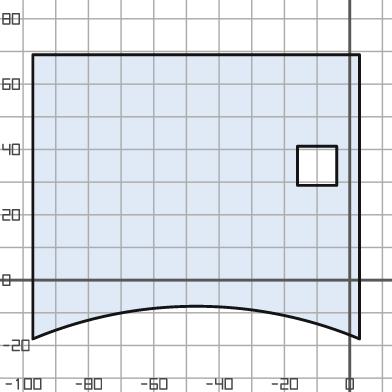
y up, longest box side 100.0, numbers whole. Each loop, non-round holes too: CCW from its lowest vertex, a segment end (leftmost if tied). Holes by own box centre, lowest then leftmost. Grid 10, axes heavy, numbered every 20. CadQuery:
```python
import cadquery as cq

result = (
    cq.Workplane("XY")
    .moveTo(-97.0, -18.0)
    .threePointArc((-47.0, -8.0), (3.0, -18.0))
    .lineTo(3.0, 69.0)
    .lineTo(-97.0, 69.0)
    .close()
    .moveTo(-16.0, 29.0)
    .lineTo(-4.0, 29.0)
    .lineTo(-4.0, 41.0)
    .lineTo(-16.0, 41.0)
    .close()
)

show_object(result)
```